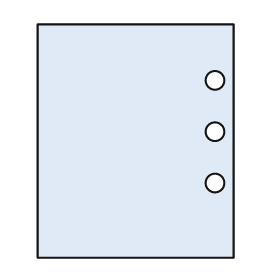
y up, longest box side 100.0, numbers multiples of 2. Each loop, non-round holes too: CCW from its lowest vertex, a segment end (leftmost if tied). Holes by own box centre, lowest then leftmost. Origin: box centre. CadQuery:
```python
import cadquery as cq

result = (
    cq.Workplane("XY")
    .moveTo(-42.0, -50.0)
    .lineTo(42.0, -50.0)
    .lineTo(42.0, 50.0)
    .lineTo(-42.0, 50.0)
    .close()
    .moveTo(34.0, -18.0)
    .circle(4.0)
    .moveTo(34.0, 4.0)
    .circle(4.0)
    .moveTo(34.0, 26.0)
    .circle(4.0)
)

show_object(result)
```